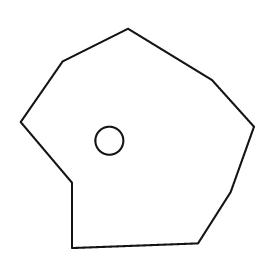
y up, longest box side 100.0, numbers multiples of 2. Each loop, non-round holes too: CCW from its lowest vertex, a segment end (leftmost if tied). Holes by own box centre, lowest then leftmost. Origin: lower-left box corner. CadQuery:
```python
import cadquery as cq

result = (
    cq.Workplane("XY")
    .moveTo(22.0, 0.0)
    .lineTo(76.0, 2.0)
    .lineTo(90.0, 24.0)
    .lineTo(100.0, 52.0)
    .lineTo(82.0, 72.0)
    .lineTo(46.0, 94.0)
    .lineTo(18.0, 80.0)
    .lineTo(0.0, 54.0)
    .lineTo(22.0, 28.0)
    .close()
    .moveTo(38.0, 46.0)
    .circle(6.0)
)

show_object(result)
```